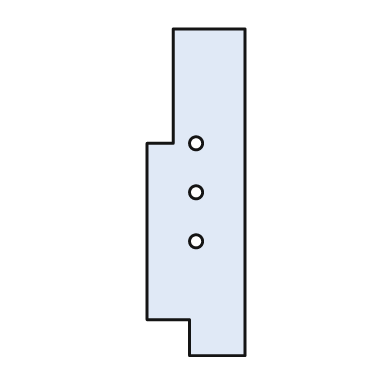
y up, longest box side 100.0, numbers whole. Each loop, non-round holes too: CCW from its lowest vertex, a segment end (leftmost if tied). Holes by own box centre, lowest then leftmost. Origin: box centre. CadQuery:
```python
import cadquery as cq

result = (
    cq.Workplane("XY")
    .moveTo(-2.0, -50.0)
    .lineTo(15.0, -50.0)
    .lineTo(15.0, 50.0)
    .lineTo(-7.0, 50.0)
    .lineTo(-7.0, 15.0)
    .lineTo(-15.0, 15.0)
    .lineTo(-15.0, -39.0)
    .lineTo(-2.0, -39.0)
    .close()
    .moveTo(0.0, -15.0)
    .circle(2.0)
    .moveTo(0.0, 0.0)
    .circle(2.0)
    .moveTo(0.0, 15.0)
    .circle(2.0)
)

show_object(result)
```